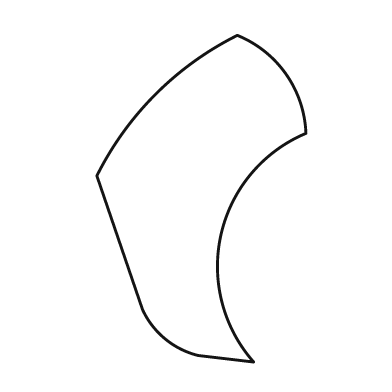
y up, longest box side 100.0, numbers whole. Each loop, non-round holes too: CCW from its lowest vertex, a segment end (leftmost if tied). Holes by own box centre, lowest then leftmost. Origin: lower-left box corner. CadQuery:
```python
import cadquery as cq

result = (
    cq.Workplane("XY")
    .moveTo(48.0, 0.0)
    .threePointArc((38.0, 39.0), (64.0, 70.0))
    .threePointArc((58.0, 88.0), (43.0, 100.0))
    .threePointArc((18.0, 82.0), (0.0, 57.0))
    .lineTo(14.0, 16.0)
    .threePointArc((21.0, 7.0), (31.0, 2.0))
    .close()
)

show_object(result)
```